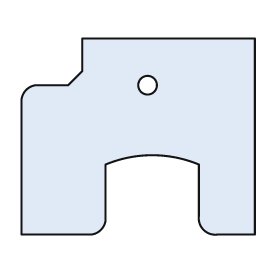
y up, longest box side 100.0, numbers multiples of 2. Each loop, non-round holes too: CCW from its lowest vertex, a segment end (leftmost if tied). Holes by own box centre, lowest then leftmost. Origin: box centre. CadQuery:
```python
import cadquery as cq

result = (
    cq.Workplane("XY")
    .moveTo(-50.0, -42.0)
    .lineTo(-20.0, -42.0)
    .threePointArc((-16.0, -40.0), (-14.0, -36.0))
    .lineTo(-14.0, -12.0)
    .threePointArc((6.0, -8.0), (26.0, -12.0))
    .lineTo(26.0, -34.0)
    .threePointArc((28.0, -40.0), (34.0, -42.0))
    .lineTo(50.0, -42.0)
    .lineTo(50.0, 42.0)
    .lineTo(-24.0, 42.0)
    .lineTo(-24.0, 28.0)
    .lineTo(-30.0, 22.0)
    .lineTo(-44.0, 22.0)
    .threePointArc((-48.0, 20.0), (-50.0, 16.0))
    .close()
    .moveTo(4.0, 22.0)
    .circle(4.0)
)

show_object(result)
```